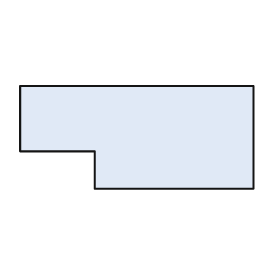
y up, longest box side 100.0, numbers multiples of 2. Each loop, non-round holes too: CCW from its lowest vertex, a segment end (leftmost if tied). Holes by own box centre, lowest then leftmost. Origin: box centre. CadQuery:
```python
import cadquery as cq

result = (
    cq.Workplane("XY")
    .moveTo(-18.0, -22.0)
    .lineTo(50.0, -22.0)
    .lineTo(50.0, 22.0)
    .lineTo(-50.0, 22.0)
    .lineTo(-50.0, -6.0)
    .lineTo(-18.0, -6.0)
    .close()
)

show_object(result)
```